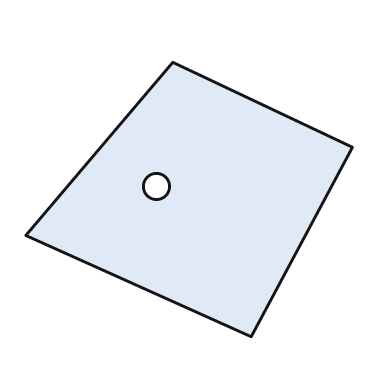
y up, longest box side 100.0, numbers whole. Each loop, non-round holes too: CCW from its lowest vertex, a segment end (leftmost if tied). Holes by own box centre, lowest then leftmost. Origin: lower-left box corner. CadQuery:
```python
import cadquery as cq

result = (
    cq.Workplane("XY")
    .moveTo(69.0, 0.0)
    .lineTo(100.0, 58.0)
    .lineTo(45.0, 84.0)
    .lineTo(0.0, 31.0)
    .close()
    .moveTo(40.0, 46.0)
    .circle(4.0)
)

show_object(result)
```